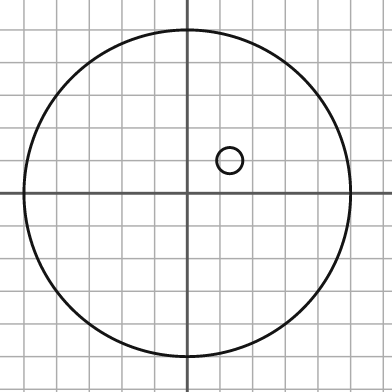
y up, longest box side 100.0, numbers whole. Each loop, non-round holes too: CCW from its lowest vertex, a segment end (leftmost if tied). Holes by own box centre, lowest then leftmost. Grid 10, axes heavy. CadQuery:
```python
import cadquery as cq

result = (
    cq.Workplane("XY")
    .moveTo(0.0, 0.0)
    .circle(50.0)
    .moveTo(13.0, 10.0)
    .circle(4.0)
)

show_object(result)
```